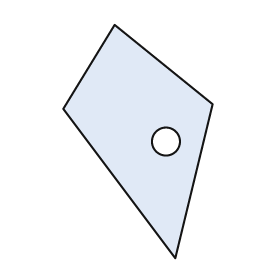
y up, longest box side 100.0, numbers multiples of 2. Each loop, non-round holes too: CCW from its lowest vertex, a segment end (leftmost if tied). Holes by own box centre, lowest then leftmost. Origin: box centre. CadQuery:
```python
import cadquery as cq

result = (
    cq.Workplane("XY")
    .moveTo(16.0, -50.0)
    .lineTo(32.0, 16.0)
    .lineTo(-10.0, 50.0)
    .lineTo(-32.0, 14.0)
    .close()
    .moveTo(12.0, 0.0)
    .circle(6.0)
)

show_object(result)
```